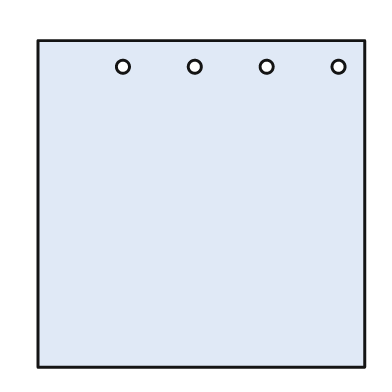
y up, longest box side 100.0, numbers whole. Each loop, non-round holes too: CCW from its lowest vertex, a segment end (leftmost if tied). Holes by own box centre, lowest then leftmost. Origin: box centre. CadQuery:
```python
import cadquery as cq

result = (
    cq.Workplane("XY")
    .moveTo(-50.0, -50.0)
    .lineTo(50.0, -50.0)
    .lineTo(50.0, 50.0)
    .lineTo(-50.0, 50.0)
    .close()
    .moveTo(-24.0, 42.0)
    .circle(2.0)
    .moveTo(-2.0, 42.0)
    .circle(2.0)
    .moveTo(20.0, 42.0)
    .circle(2.0)
    .moveTo(42.0, 42.0)
    .circle(2.0)
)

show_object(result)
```